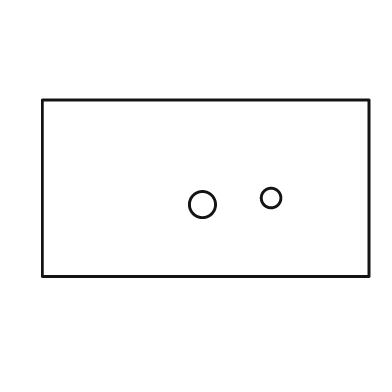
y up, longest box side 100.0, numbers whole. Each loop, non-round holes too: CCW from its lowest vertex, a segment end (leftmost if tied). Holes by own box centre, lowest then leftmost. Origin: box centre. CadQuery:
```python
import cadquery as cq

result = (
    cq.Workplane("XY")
    .moveTo(-50.0, -27.0)
    .lineTo(50.0, -27.0)
    .lineTo(50.0, 27.0)
    .lineTo(-50.0, 27.0)
    .close()
    .moveTo(-1.0, -5.0)
    .circle(4.0)
    .moveTo(20.0, -3.0)
    .circle(3.0)
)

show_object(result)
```